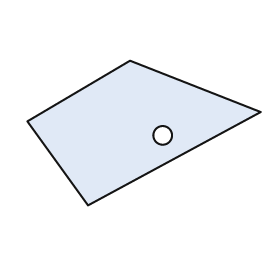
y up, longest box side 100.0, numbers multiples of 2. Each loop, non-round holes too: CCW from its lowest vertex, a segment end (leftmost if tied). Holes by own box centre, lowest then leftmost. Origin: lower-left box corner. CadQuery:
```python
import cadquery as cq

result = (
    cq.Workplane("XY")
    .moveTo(26.0, 0.0)
    .lineTo(100.0, 40.0)
    .lineTo(44.0, 62.0)
    .lineTo(0.0, 36.0)
    .close()
    .moveTo(58.0, 30.0)
    .circle(4.0)
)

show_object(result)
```